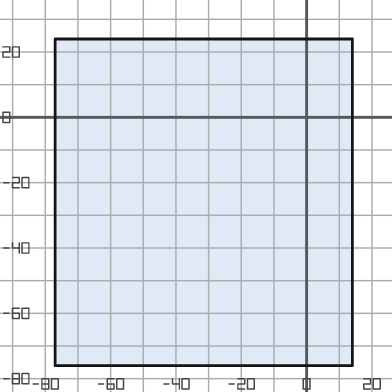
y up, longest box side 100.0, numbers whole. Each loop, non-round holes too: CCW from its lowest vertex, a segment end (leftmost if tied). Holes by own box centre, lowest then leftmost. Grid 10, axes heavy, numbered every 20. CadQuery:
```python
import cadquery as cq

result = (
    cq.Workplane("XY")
    .moveTo(-77.0, -76.0)
    .lineTo(14.0, -76.0)
    .lineTo(14.0, 24.0)
    .lineTo(-77.0, 24.0)
    .close()
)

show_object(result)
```